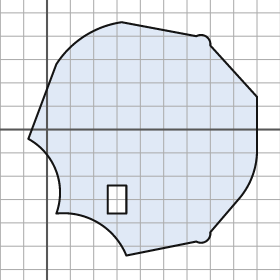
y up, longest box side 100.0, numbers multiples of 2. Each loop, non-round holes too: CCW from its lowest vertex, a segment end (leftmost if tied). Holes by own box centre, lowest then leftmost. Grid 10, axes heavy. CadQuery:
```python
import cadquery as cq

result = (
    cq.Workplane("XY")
    .moveTo(34.0, -54.0)
    .lineTo(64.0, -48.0)
    .threePointArc((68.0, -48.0), (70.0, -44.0))
    .lineTo(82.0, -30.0)
    .threePointArc((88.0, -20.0), (90.0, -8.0))
    .lineTo(90.0, 14.0)
    .lineTo(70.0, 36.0)
    .threePointArc((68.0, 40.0), (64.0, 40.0))
    .lineTo(32.0, 46.0)
    .threePointArc((16.0, 40.0), (4.0, 28.0))
    .lineTo(-8.0, -4.0)
    .threePointArc((4.0, -18.0), (4.0, -36.0))
    .threePointArc((22.0, -40.0), (34.0, -54.0))
    .close()
    .moveTo(26.0, -36.0)
    .lineTo(34.0, -36.0)
    .lineTo(34.0, -24.0)
    .lineTo(26.0, -24.0)
    .close()
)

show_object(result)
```